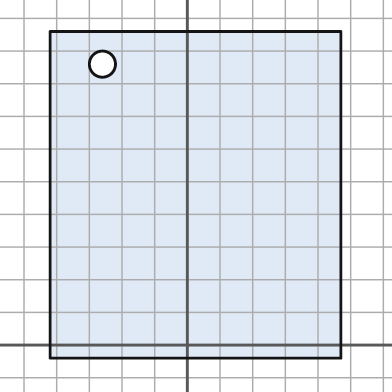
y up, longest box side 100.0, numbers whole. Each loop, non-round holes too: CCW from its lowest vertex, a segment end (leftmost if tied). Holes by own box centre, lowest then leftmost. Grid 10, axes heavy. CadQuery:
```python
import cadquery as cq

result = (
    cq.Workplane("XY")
    .moveTo(-42.0, -4.0)
    .lineTo(47.0, -4.0)
    .lineTo(47.0, 96.0)
    .lineTo(-42.0, 96.0)
    .close()
    .moveTo(-26.0, 86.0)
    .circle(4.0)
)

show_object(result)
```